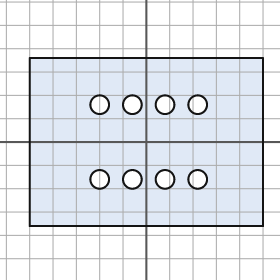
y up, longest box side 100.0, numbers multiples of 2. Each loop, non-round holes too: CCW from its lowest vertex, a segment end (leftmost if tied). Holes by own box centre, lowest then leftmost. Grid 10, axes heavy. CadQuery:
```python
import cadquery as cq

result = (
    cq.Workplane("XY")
    .moveTo(-50.0, -36.0)
    .lineTo(50.0, -36.0)
    .lineTo(50.0, 36.0)
    .lineTo(-50.0, 36.0)
    .close()
    .moveTo(-20.0, -16.0)
    .circle(4.0)
    .moveTo(-6.0, -16.0)
    .circle(4.0)
    .moveTo(8.0, -16.0)
    .circle(4.0)
    .moveTo(22.0, -16.0)
    .circle(4.0)
    .moveTo(-20.0, 16.0)
    .circle(4.0)
    .moveTo(-6.0, 16.0)
    .circle(4.0)
    .moveTo(8.0, 16.0)
    .circle(4.0)
    .moveTo(22.0, 16.0)
    .circle(4.0)
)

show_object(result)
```